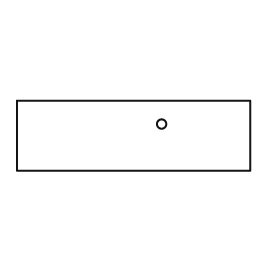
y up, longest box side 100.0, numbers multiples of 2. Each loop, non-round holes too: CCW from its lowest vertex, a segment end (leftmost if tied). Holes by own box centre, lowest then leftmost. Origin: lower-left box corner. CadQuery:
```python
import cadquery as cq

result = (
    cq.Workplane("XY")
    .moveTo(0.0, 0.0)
    .lineTo(100.0, 0.0)
    .lineTo(100.0, 30.0)
    .lineTo(0.0, 30.0)
    .close()
    .moveTo(62.0, 20.0)
    .circle(2.0)
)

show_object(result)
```